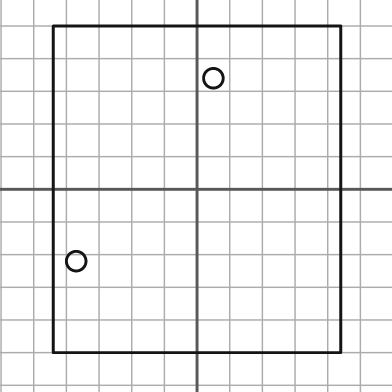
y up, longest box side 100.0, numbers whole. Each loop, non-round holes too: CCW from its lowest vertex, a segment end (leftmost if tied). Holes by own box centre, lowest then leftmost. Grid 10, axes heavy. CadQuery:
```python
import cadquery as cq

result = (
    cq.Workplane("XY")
    .moveTo(-44.0, -50.0)
    .lineTo(44.0, -50.0)
    .lineTo(44.0, 50.0)
    .lineTo(-44.0, 50.0)
    .close()
    .moveTo(-37.0, -22.0)
    .circle(3.0)
    .moveTo(5.0, 34.0)
    .circle(3.0)
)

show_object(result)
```